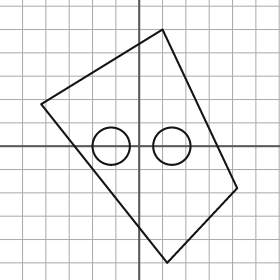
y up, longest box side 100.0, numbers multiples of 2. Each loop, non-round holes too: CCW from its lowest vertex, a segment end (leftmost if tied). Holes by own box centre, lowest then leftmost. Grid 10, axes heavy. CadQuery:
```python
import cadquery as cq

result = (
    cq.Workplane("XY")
    .moveTo(12.0, -50.0)
    .lineTo(42.0, -18.0)
    .lineTo(10.0, 50.0)
    .lineTo(-42.0, 18.0)
    .close()
    .moveTo(-12.0, 0.0)
    .circle(8.0)
    .moveTo(14.0, 0.0)
    .circle(8.0)
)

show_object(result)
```